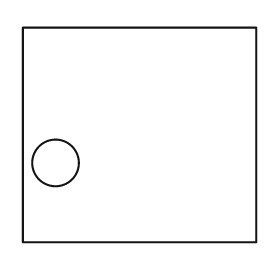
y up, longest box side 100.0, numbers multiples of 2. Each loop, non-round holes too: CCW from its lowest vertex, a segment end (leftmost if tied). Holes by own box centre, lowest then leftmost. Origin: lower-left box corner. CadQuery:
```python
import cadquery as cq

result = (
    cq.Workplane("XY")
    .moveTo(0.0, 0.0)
    .lineTo(100.0, 0.0)
    .lineTo(100.0, 92.0)
    .lineTo(0.0, 92.0)
    .close()
    .moveTo(14.0, 34.0)
    .circle(10.0)
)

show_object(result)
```